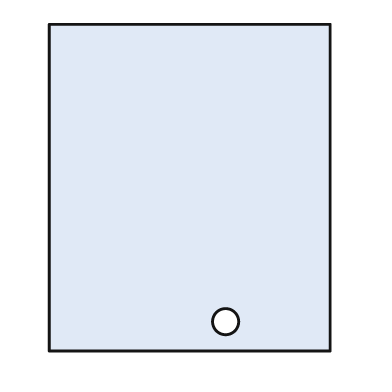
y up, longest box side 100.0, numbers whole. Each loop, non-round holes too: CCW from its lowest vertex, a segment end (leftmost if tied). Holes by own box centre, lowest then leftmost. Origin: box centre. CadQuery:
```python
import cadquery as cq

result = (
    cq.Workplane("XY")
    .moveTo(-43.0, -50.0)
    .lineTo(43.0, -50.0)
    .lineTo(43.0, 50.0)
    .lineTo(-43.0, 50.0)
    .close()
    .moveTo(11.0, -41.0)
    .circle(4.0)
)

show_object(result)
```